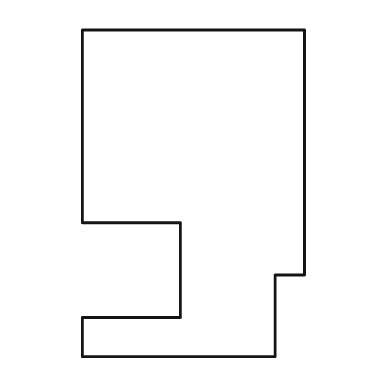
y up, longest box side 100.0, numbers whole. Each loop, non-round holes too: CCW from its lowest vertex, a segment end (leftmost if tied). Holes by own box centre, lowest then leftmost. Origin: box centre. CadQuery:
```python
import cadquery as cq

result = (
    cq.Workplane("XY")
    .moveTo(-34.0, -50.0)
    .lineTo(25.0, -50.0)
    .lineTo(25.0, -25.0)
    .lineTo(34.0, -25.0)
    .lineTo(34.0, 50.0)
    .lineTo(-34.0, 50.0)
    .lineTo(-34.0, -9.0)
    .lineTo(-4.0, -9.0)
    .lineTo(-4.0, -38.0)
    .lineTo(-34.0, -38.0)
    .close()
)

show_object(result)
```